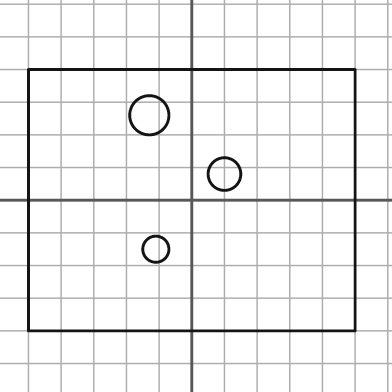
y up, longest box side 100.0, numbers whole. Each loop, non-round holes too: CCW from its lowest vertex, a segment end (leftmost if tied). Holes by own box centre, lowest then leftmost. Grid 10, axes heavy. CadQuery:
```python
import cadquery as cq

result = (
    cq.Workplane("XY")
    .moveTo(-50.0, -40.0)
    .lineTo(50.0, -40.0)
    .lineTo(50.0, 40.0)
    .lineTo(-50.0, 40.0)
    .close()
    .moveTo(-11.0, -15.0)
    .circle(4.0)
    .moveTo(10.0, 8.0)
    .circle(5.0)
    .moveTo(-13.0, 26.0)
    .circle(6.0)
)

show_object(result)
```